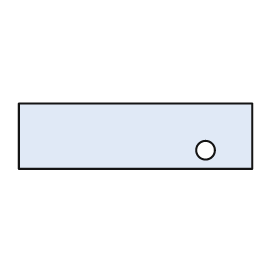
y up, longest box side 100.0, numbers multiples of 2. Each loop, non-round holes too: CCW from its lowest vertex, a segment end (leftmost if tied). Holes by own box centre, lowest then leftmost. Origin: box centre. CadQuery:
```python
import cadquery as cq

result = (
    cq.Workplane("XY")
    .moveTo(-50.0, -14.0)
    .lineTo(50.0, -14.0)
    .lineTo(50.0, 14.0)
    .lineTo(-50.0, 14.0)
    .close()
    .moveTo(30.0, -6.0)
    .circle(4.0)
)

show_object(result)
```